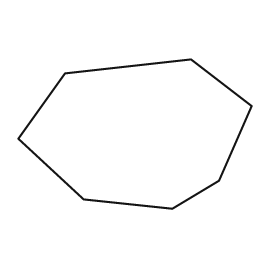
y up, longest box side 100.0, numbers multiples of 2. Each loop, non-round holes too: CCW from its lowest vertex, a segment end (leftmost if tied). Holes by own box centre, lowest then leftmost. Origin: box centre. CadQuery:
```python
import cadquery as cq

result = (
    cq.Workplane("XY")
    .moveTo(16.0, -32.0)
    .lineTo(36.0, -20.0)
    .lineTo(50.0, 12.0)
    .lineTo(24.0, 32.0)
    .lineTo(-30.0, 26.0)
    .lineTo(-50.0, -2.0)
    .lineTo(-22.0, -28.0)
    .close()
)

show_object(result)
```